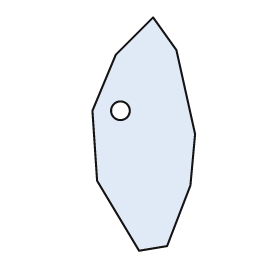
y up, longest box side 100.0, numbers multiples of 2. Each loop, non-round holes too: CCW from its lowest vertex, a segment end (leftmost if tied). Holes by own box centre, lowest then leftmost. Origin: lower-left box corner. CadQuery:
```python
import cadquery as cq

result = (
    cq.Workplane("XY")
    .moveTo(20.0, 0.0)
    .lineTo(32.0, 2.0)
    .lineTo(42.0, 28.0)
    .lineTo(44.0, 50.0)
    .lineTo(36.0, 86.0)
    .lineTo(26.0, 100.0)
    .lineTo(10.0, 84.0)
    .lineTo(0.0, 60.0)
    .lineTo(2.0, 30.0)
    .close()
    .moveTo(12.0, 60.0)
    .circle(4.0)
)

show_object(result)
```